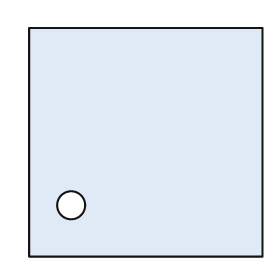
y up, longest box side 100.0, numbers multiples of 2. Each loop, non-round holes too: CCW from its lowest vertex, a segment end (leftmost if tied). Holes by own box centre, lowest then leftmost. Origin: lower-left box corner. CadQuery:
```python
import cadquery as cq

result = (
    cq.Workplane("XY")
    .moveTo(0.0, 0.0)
    .lineTo(100.0, 0.0)
    .lineTo(100.0, 98.0)
    .lineTo(0.0, 98.0)
    .close()
    .moveTo(18.0, 22.0)
    .circle(6.0)
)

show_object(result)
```